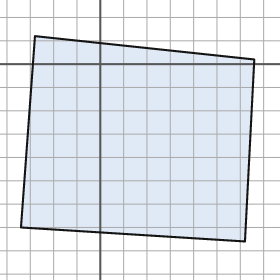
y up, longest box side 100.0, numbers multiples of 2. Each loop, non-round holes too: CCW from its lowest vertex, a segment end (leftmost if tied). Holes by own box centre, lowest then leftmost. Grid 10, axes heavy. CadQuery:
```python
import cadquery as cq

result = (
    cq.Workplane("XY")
    .moveTo(62.0, -76.0)
    .lineTo(66.0, 2.0)
    .lineTo(-28.0, 12.0)
    .lineTo(-34.0, -70.0)
    .close()
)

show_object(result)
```